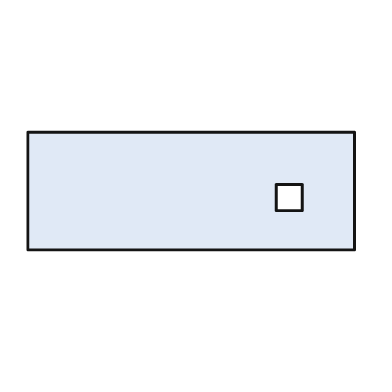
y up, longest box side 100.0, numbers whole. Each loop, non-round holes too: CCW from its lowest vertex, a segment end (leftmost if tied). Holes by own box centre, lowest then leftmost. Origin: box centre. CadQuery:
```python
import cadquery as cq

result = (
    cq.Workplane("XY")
    .moveTo(-50.0, -18.0)
    .lineTo(50.0, -18.0)
    .lineTo(50.0, 18.0)
    .lineTo(-50.0, 18.0)
    .close()
    .moveTo(26.0, -6.0)
    .lineTo(34.0, -6.0)
    .lineTo(34.0, 2.0)
    .lineTo(26.0, 2.0)
    .close()
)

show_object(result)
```